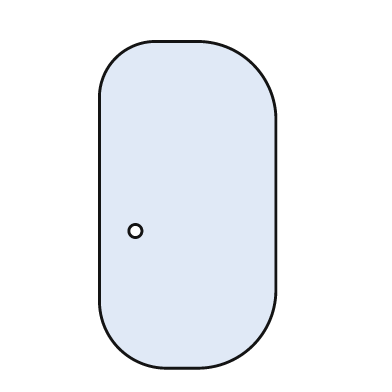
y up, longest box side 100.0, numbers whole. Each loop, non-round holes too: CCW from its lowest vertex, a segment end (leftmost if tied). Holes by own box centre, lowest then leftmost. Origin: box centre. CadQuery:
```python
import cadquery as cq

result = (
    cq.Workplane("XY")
    .moveTo(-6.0, -50.0)
    .lineTo(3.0, -50.0)
    .threePointArc((20.0, -43.0), (27.0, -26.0))
    .lineTo(27.0, 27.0)
    .threePointArc((20.0, 43.0), (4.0, 50.0))
    .lineTo(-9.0, 50.0)
    .threePointArc((-22.0, 45.0), (-27.0, 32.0))
    .lineTo(-27.0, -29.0)
    .threePointArc((-21.0, -44.0), (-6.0, -50.0))
    .close()
    .moveTo(-16.0, -8.0)
    .circle(2.0)
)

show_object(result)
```